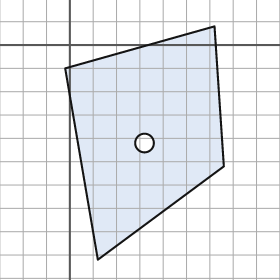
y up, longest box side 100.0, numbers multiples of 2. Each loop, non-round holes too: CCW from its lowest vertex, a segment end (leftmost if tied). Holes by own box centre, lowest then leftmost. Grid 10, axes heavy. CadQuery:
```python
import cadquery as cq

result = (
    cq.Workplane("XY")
    .moveTo(12.0, -92.0)
    .lineTo(66.0, -52.0)
    .lineTo(62.0, 8.0)
    .lineTo(-2.0, -10.0)
    .close()
    .moveTo(32.0, -42.0)
    .circle(4.0)
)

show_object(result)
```